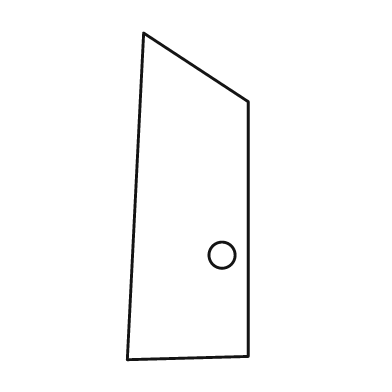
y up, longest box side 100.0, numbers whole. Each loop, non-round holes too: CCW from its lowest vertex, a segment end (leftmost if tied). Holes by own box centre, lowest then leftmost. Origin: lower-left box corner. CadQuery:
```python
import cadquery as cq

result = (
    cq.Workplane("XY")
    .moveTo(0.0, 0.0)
    .lineTo(37.0, 1.0)
    .lineTo(37.0, 79.0)
    .lineTo(5.0, 100.0)
    .close()
    .moveTo(29.0, 32.0)
    .circle(4.0)
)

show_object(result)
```